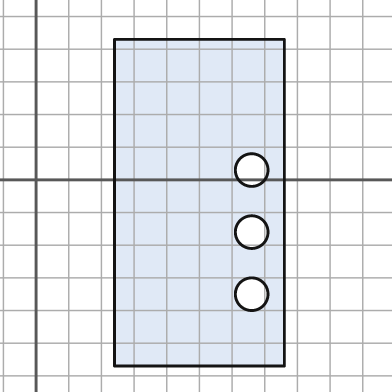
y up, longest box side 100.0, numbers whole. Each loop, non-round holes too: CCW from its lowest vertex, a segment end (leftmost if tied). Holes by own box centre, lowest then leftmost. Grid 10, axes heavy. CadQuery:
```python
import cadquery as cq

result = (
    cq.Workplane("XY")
    .moveTo(24.0, -57.0)
    .lineTo(76.0, -57.0)
    .lineTo(76.0, 43.0)
    .lineTo(24.0, 43.0)
    .close()
    .moveTo(66.0, -35.0)
    .circle(5.0)
    .moveTo(66.0, -16.0)
    .circle(5.0)
    .moveTo(66.0, 3.0)
    .circle(5.0)
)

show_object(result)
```